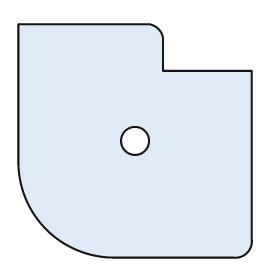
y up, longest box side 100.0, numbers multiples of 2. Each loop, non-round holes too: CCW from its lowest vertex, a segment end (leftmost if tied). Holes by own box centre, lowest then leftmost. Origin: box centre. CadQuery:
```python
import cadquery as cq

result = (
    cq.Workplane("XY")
    .moveTo(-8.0, -50.0)
    .lineTo(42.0, -50.0)
    .threePointArc((48.0, -48.0), (50.0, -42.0))
    .lineTo(50.0, 30.0)
    .lineTo(12.0, 30.0)
    .lineTo(12.0, 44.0)
    .threePointArc((10.0, 48.0), (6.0, 50.0))
    .lineTo(-50.0, 50.0)
    .lineTo(-50.0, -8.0)
    .threePointArc((-38.0, -38.0), (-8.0, -50.0))
    .close()
    .moveTo(0.0, 0.0)
    .circle(6.0)
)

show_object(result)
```